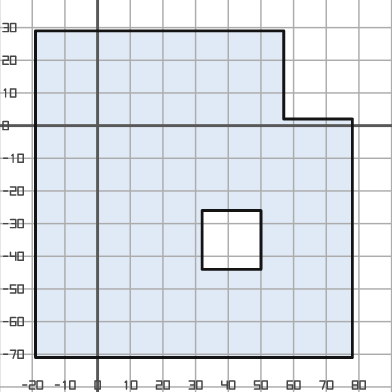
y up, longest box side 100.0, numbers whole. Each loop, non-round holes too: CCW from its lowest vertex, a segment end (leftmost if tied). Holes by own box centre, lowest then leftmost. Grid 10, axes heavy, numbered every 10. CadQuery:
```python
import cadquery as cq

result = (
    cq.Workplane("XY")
    .moveTo(-19.0, -71.0)
    .lineTo(78.0, -71.0)
    .lineTo(78.0, 2.0)
    .lineTo(57.0, 2.0)
    .lineTo(57.0, 29.0)
    .lineTo(-19.0, 29.0)
    .close()
    .moveTo(32.0, -44.0)
    .lineTo(50.0, -44.0)
    .lineTo(50.0, -26.0)
    .lineTo(32.0, -26.0)
    .close()
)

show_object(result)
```